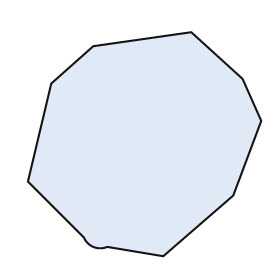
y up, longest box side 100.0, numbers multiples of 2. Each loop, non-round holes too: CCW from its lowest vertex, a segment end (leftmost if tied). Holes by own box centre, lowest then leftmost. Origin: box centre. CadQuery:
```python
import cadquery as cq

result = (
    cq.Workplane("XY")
    .moveTo(8.0, -48.0)
    .lineTo(38.0, -22.0)
    .lineTo(50.0, 10.0)
    .lineTo(42.0, 28.0)
    .lineTo(20.0, 48.0)
    .lineTo(-22.0, 42.0)
    .lineTo(-40.0, 26.0)
    .lineTo(-50.0, -16.0)
    .lineTo(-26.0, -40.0)
    .threePointArc((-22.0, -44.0), (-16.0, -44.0))
    .close()
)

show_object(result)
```